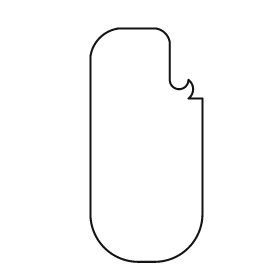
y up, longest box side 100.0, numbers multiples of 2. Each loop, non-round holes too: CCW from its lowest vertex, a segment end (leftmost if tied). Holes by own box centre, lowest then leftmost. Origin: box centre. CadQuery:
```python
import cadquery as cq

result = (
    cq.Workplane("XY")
    .moveTo(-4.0, -50.0)
    .lineTo(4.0, -50.0)
    .threePointArc((18.0, -44.0), (24.0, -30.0))
    .lineTo(24.0, 20.0)
    .lineTo(18.0, 20.0)
    .threePointArc((20.0, 24.0), (18.0, 28.0))
    .threePointArc((14.0, 24.0), (10.0, 28.0))
    .lineTo(10.0, 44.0)
    .threePointArc((8.0, 48.0), (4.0, 50.0))
    .lineTo(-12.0, 50.0)
    .threePointArc((-20.0, 46.0), (-24.0, 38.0))
    .lineTo(-24.0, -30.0)
    .threePointArc((-18.0, -44.0), (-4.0, -50.0))
    .close()
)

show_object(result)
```